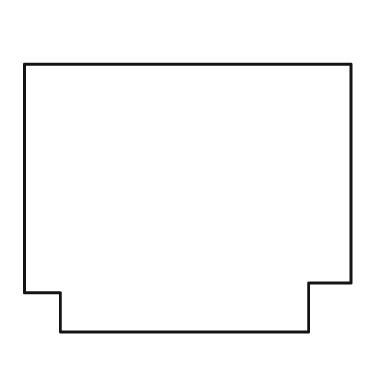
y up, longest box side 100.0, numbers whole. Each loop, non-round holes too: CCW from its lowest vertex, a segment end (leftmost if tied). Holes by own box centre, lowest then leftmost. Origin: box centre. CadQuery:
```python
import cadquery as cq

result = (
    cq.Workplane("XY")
    .moveTo(-39.0, -41.0)
    .lineTo(37.0, -41.0)
    .lineTo(37.0, -26.0)
    .lineTo(50.0, -26.0)
    .lineTo(50.0, 41.0)
    .lineTo(-50.0, 41.0)
    .lineTo(-50.0, -29.0)
    .lineTo(-39.0, -29.0)
    .close()
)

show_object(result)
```